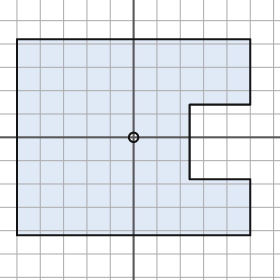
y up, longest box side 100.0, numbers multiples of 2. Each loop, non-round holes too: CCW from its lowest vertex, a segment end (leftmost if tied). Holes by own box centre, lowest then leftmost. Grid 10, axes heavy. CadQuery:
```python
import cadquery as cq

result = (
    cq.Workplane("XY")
    .moveTo(-50.0, -42.0)
    .lineTo(50.0, -42.0)
    .lineTo(50.0, -18.0)
    .lineTo(24.0, -18.0)
    .lineTo(24.0, 14.0)
    .lineTo(50.0, 14.0)
    .lineTo(50.0, 42.0)
    .lineTo(-50.0, 42.0)
    .close()
    .moveTo(0.0, 0.0)
    .circle(2.0)
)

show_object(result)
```